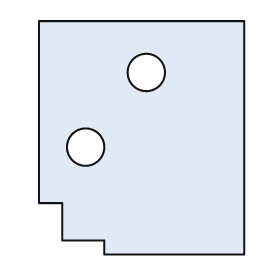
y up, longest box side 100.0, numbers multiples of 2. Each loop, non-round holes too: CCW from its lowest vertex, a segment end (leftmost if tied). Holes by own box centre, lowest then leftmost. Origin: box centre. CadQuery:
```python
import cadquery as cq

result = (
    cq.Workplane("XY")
    .moveTo(-16.0, -50.0)
    .lineTo(44.0, -50.0)
    .lineTo(44.0, 50.0)
    .lineTo(-44.0, 50.0)
    .lineTo(-44.0, -28.0)
    .lineTo(-34.0, -28.0)
    .lineTo(-34.0, -44.0)
    .lineTo(-16.0, -44.0)
    .close()
    .moveTo(-24.0, -4.0)
    .circle(8.0)
    .moveTo(2.0, 28.0)
    .circle(8.0)
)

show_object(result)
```